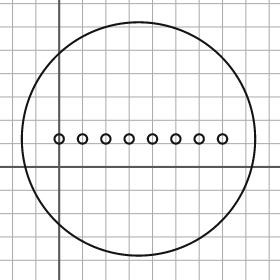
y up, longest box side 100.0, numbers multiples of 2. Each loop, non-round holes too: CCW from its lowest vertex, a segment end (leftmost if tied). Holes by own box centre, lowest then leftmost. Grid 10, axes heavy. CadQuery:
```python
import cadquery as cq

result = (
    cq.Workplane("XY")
    .moveTo(34.0, 12.0)
    .circle(50.0)
    .moveTo(0.0, 12.0)
    .circle(2.0)
    .moveTo(10.0, 12.0)
    .circle(2.0)
    .moveTo(20.0, 12.0)
    .circle(2.0)
    .moveTo(30.0, 12.0)
    .circle(2.0)
    .moveTo(40.0, 12.0)
    .circle(2.0)
    .moveTo(50.0, 12.0)
    .circle(2.0)
    .moveTo(60.0, 12.0)
    .circle(2.0)
    .moveTo(70.0, 12.0)
    .circle(2.0)
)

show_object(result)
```